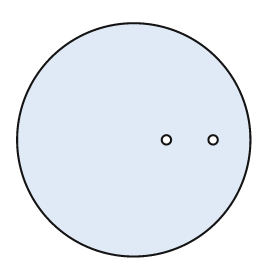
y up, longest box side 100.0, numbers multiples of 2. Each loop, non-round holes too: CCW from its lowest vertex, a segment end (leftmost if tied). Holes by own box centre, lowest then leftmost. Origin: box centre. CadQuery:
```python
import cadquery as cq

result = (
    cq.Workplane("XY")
    .moveTo(0.0, 0.0)
    .circle(50.0)
    .moveTo(14.0, 0.0)
    .circle(2.0)
    .moveTo(34.0, 0.0)
    .circle(2.0)
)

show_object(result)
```